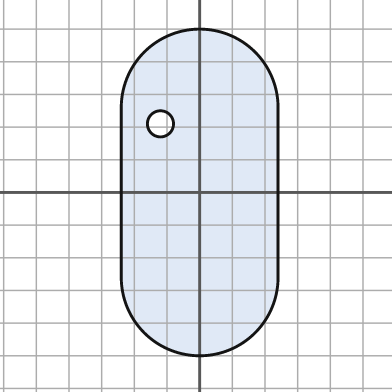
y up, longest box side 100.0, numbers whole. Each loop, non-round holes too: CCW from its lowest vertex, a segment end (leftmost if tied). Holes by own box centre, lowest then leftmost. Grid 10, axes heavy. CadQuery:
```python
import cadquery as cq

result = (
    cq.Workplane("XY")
    .moveTo(-24.0, -26.0)
    .threePointArc((0.0, -50.0), (24.0, -26.0))
    .lineTo(24.0, 26.0)
    .threePointArc((0.0, 50.0), (-24.0, 26.0))
    .close()
    .moveTo(-12.0, 21.0)
    .circle(4.0)
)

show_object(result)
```